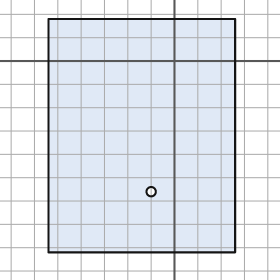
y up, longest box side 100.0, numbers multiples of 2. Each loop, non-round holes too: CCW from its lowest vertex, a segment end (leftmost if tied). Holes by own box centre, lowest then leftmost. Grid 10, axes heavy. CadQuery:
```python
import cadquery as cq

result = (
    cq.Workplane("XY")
    .moveTo(-54.0, -82.0)
    .lineTo(26.0, -82.0)
    .lineTo(26.0, 18.0)
    .lineTo(-54.0, 18.0)
    .close()
    .moveTo(-10.0, -56.0)
    .circle(2.0)
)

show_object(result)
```